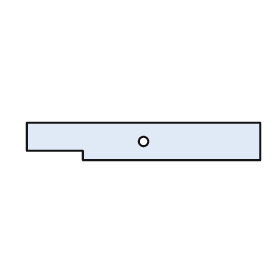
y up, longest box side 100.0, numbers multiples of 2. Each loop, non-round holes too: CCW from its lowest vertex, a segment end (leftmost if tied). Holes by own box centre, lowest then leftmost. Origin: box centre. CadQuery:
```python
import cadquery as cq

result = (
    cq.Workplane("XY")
    .moveTo(-26.0, -8.0)
    .lineTo(50.0, -8.0)
    .lineTo(50.0, 8.0)
    .lineTo(-50.0, 8.0)
    .lineTo(-50.0, -4.0)
    .lineTo(-26.0, -4.0)
    .close()
    .moveTo(0.0, 0.0)
    .circle(2.0)
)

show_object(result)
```